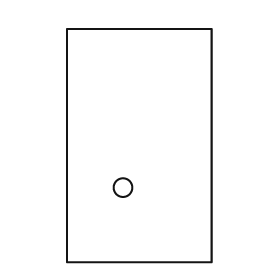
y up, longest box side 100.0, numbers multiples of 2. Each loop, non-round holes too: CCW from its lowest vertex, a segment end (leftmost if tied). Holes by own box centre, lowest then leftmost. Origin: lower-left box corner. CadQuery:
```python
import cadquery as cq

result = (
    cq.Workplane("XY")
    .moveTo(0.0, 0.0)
    .lineTo(62.0, 0.0)
    .lineTo(62.0, 100.0)
    .lineTo(0.0, 100.0)
    .close()
    .moveTo(24.0, 32.0)
    .circle(4.0)
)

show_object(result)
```